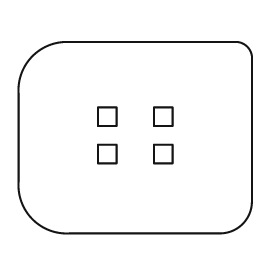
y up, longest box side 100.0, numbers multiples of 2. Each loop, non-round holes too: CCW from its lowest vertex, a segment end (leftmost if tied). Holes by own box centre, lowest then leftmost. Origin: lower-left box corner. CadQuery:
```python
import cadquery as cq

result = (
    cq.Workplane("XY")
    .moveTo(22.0, 0.0)
    .lineTo(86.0, 0.0)
    .threePointArc((96.0, 4.0), (100.0, 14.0))
    .lineTo(100.0, 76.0)
    .threePointArc((98.0, 80.0), (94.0, 82.0))
    .lineTo(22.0, 82.0)
    .threePointArc((6.0, 76.0), (0.0, 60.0))
    .lineTo(0.0, 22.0)
    .threePointArc((6.0, 6.0), (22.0, 0.0))
    .close()
    .moveTo(34.0, 30.0)
    .lineTo(42.0, 30.0)
    .lineTo(42.0, 38.0)
    .lineTo(34.0, 38.0)
    .close()
    .moveTo(58.0, 30.0)
    .lineTo(66.0, 30.0)
    .lineTo(66.0, 38.0)
    .lineTo(58.0, 38.0)
    .close()
    .moveTo(34.0, 46.0)
    .lineTo(42.0, 46.0)
    .lineTo(42.0, 54.0)
    .lineTo(34.0, 54.0)
    .close()
    .moveTo(58.0, 46.0)
    .lineTo(66.0, 46.0)
    .lineTo(66.0, 54.0)
    .lineTo(58.0, 54.0)
    .close()
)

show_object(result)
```